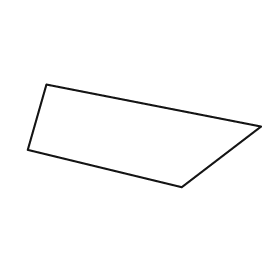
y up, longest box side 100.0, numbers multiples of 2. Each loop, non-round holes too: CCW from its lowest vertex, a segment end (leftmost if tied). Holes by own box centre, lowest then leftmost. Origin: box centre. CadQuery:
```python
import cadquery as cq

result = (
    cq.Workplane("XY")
    .moveTo(16.0, -22.0)
    .lineTo(50.0, 4.0)
    .lineTo(-42.0, 22.0)
    .lineTo(-50.0, -6.0)
    .close()
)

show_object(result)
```